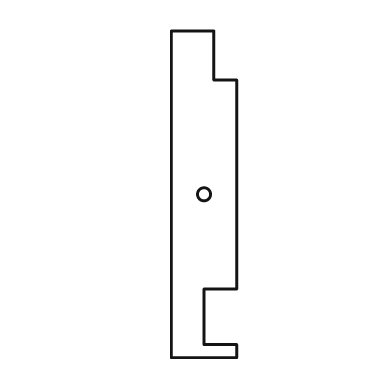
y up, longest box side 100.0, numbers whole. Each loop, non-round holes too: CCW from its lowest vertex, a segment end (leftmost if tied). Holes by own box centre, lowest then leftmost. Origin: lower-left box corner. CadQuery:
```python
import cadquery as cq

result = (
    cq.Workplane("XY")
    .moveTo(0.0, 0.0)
    .lineTo(20.0, 0.0)
    .lineTo(20.0, 4.0)
    .lineTo(10.0, 4.0)
    .lineTo(10.0, 21.0)
    .lineTo(20.0, 21.0)
    .lineTo(20.0, 85.0)
    .lineTo(13.0, 85.0)
    .lineTo(13.0, 100.0)
    .lineTo(0.0, 100.0)
    .close()
    .moveTo(10.0, 50.0)
    .circle(2.0)
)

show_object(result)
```